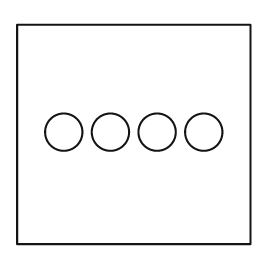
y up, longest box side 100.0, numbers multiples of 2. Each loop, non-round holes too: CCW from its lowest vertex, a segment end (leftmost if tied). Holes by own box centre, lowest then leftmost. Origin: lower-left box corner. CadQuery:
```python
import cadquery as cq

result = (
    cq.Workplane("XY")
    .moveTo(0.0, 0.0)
    .lineTo(100.0, 0.0)
    .lineTo(100.0, 94.0)
    .lineTo(0.0, 94.0)
    .close()
    .moveTo(20.0, 48.0)
    .circle(8.0)
    .moveTo(40.0, 48.0)
    .circle(8.0)
    .moveTo(60.0, 48.0)
    .circle(8.0)
    .moveTo(80.0, 48.0)
    .circle(8.0)
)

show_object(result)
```